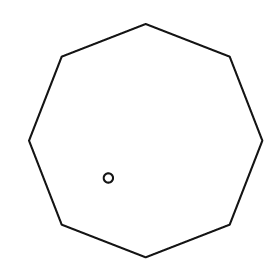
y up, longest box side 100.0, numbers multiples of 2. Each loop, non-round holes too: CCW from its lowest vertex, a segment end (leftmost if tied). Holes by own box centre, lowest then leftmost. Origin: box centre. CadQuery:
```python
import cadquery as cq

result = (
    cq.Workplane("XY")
    .moveTo(0.0, -50.0)
    .lineTo(36.0, -36.0)
    .lineTo(50.0, 0.0)
    .lineTo(36.0, 36.0)
    .lineTo(0.0, 50.0)
    .lineTo(-36.0, 36.0)
    .lineTo(-50.0, 0.0)
    .lineTo(-36.0, -36.0)
    .close()
    .moveTo(-16.0, -16.0)
    .circle(2.0)
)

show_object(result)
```